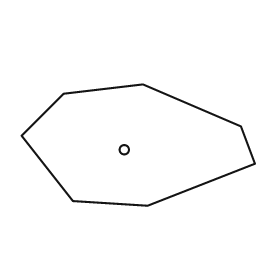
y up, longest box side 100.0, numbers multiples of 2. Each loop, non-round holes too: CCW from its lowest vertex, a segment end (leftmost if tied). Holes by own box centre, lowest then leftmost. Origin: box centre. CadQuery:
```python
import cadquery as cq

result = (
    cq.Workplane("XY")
    .moveTo(4.0, -26.0)
    .lineTo(50.0, -8.0)
    .lineTo(44.0, 8.0)
    .lineTo(2.0, 26.0)
    .lineTo(-32.0, 22.0)
    .lineTo(-50.0, 4.0)
    .lineTo(-28.0, -24.0)
    .close()
    .moveTo(-6.0, -2.0)
    .circle(2.0)
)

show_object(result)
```